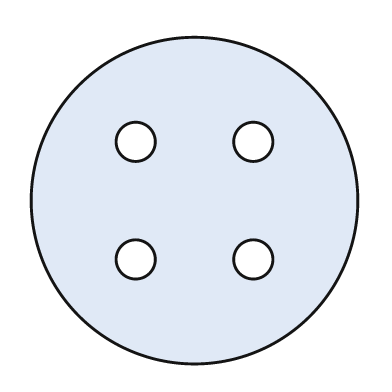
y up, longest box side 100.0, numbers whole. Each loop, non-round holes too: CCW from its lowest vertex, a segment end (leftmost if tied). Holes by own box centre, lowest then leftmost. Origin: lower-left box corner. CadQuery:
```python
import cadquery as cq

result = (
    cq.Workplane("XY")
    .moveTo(50.0, 50.0)
    .circle(50.0)
    .moveTo(32.0, 32.0)
    .circle(6.0)
    .moveTo(68.0, 32.0)
    .circle(6.0)
    .moveTo(32.0, 68.0)
    .circle(6.0)
    .moveTo(68.0, 68.0)
    .circle(6.0)
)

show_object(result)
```